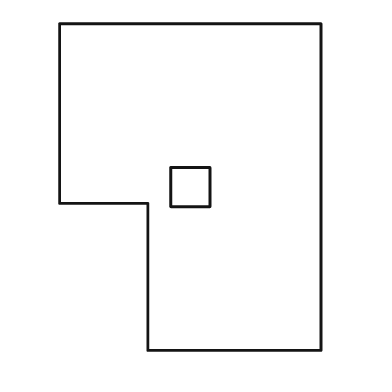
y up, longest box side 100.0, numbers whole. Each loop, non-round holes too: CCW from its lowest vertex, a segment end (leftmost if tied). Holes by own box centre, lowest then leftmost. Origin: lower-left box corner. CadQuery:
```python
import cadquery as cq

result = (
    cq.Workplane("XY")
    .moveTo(27.0, 0.0)
    .lineTo(80.0, 0.0)
    .lineTo(80.0, 100.0)
    .lineTo(0.0, 100.0)
    .lineTo(0.0, 45.0)
    .lineTo(27.0, 45.0)
    .close()
    .moveTo(34.0, 44.0)
    .lineTo(46.0, 44.0)
    .lineTo(46.0, 56.0)
    .lineTo(34.0, 56.0)
    .close()
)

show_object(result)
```